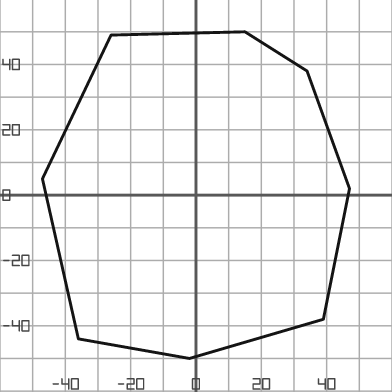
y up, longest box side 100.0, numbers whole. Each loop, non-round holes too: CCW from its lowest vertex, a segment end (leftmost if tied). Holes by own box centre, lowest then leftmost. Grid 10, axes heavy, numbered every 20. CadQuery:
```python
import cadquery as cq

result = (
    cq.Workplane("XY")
    .moveTo(-2.0, -50.0)
    .lineTo(39.0, -38.0)
    .lineTo(47.0, 2.0)
    .lineTo(34.0, 38.0)
    .lineTo(15.0, 50.0)
    .lineTo(-26.0, 49.0)
    .lineTo(-47.0, 5.0)
    .lineTo(-36.0, -44.0)
    .close()
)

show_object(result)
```